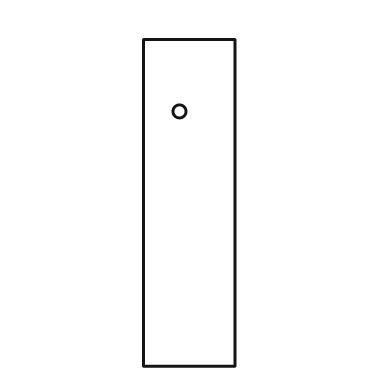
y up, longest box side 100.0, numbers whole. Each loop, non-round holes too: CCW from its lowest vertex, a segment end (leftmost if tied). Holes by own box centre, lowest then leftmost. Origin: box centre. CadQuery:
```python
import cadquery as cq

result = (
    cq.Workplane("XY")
    .moveTo(-14.0, -50.0)
    .lineTo(14.0, -50.0)
    .lineTo(14.0, 50.0)
    .lineTo(-14.0, 50.0)
    .close()
    .moveTo(-3.0, 28.0)
    .circle(2.0)
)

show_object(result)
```